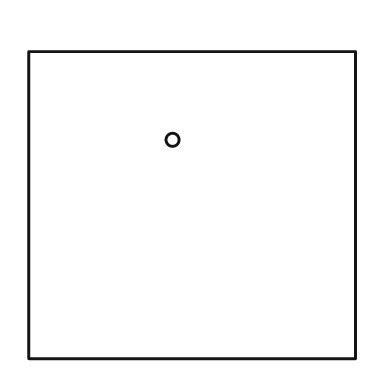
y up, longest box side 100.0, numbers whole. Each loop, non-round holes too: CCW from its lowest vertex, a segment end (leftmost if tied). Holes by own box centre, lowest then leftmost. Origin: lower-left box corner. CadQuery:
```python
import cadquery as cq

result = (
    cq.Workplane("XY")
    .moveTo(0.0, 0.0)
    .lineTo(100.0, 0.0)
    .lineTo(100.0, 94.0)
    .lineTo(0.0, 94.0)
    .close()
    .moveTo(44.0, 67.0)
    .circle(2.0)
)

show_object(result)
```